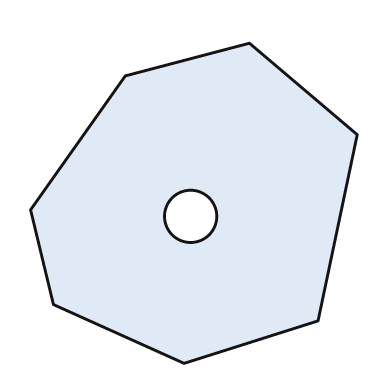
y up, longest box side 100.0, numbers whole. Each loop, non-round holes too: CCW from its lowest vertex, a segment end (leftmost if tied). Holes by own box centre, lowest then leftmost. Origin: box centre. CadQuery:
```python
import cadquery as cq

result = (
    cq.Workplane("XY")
    .moveTo(-3.0, -49.0)
    .lineTo(38.0, -36.0)
    .lineTo(50.0, 21.0)
    .lineTo(17.0, 49.0)
    .lineTo(-21.0, 39.0)
    .lineTo(-50.0, -2.0)
    .lineTo(-43.0, -31.0)
    .close()
    .moveTo(-1.0, -4.0)
    .circle(8.0)
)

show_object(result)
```